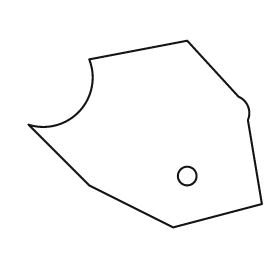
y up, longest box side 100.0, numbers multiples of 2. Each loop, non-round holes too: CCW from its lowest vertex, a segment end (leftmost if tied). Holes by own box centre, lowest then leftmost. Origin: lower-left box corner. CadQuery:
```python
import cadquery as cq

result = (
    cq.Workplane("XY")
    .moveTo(62.0, 0.0)
    .lineTo(100.0, 10.0)
    .lineTo(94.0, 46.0)
    .threePointArc((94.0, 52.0), (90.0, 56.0))
    .lineTo(68.0, 80.0)
    .lineTo(26.0, 72.0)
    .threePointArc((22.0, 50.0), (0.0, 44.0))
    .lineTo(26.0, 18.0)
    .close()
    .moveTo(68.0, 22.0)
    .circle(4.0)
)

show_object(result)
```